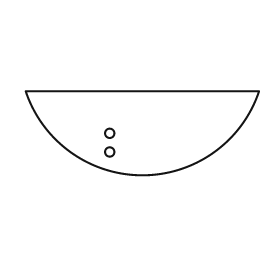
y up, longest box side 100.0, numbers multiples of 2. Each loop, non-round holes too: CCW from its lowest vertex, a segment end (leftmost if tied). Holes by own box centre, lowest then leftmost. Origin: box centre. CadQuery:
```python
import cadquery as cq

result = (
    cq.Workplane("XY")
    .moveTo(-50.0, 18.0)
    .threePointArc((0.0, -18.0), (50.0, 18.0))
    .close()
    .moveTo(-14.0, -8.0)
    .circle(2.0)
    .moveTo(-14.0, 0.0)
    .circle(2.0)
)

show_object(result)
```